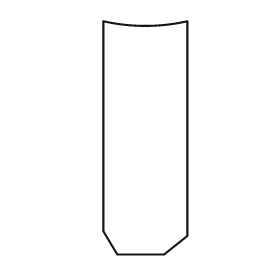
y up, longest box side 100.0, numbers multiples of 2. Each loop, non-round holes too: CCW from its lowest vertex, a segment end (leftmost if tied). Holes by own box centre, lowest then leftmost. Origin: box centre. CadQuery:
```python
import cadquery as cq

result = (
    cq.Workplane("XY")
    .moveTo(-12.0, -50.0)
    .lineTo(8.0, -50.0)
    .lineTo(18.0, -42.0)
    .lineTo(18.0, 50.0)
    .threePointArc((0.0, 48.0), (-18.0, 50.0))
    .lineTo(-18.0, -40.0)
    .close()
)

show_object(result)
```